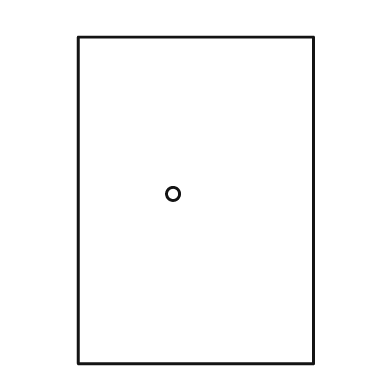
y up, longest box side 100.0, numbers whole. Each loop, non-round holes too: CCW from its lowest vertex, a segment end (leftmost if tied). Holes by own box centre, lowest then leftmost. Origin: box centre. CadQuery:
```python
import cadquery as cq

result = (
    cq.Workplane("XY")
    .moveTo(-36.0, -50.0)
    .lineTo(36.0, -50.0)
    .lineTo(36.0, 50.0)
    .lineTo(-36.0, 50.0)
    .close()
    .moveTo(-7.0, 2.0)
    .circle(2.0)
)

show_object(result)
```